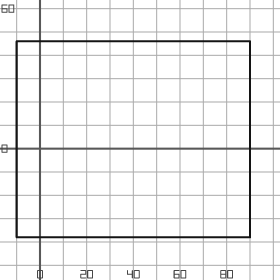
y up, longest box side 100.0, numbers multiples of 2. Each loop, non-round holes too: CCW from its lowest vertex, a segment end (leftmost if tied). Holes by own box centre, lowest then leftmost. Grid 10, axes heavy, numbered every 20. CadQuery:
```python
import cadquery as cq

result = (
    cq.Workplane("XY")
    .moveTo(-10.0, -38.0)
    .lineTo(90.0, -38.0)
    .lineTo(90.0, 46.0)
    .lineTo(-10.0, 46.0)
    .close()
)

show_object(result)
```